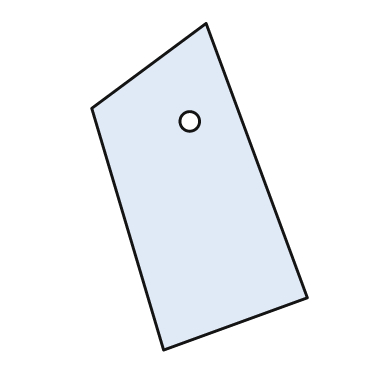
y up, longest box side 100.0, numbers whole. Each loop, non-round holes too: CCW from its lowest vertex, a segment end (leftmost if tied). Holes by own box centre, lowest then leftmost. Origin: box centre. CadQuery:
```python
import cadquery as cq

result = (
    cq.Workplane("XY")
    .moveTo(-11.0, -50.0)
    .lineTo(33.0, -34.0)
    .lineTo(2.0, 50.0)
    .lineTo(-33.0, 24.0)
    .close()
    .moveTo(-3.0, 20.0)
    .circle(3.0)
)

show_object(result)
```